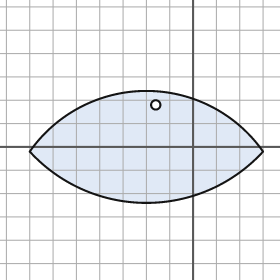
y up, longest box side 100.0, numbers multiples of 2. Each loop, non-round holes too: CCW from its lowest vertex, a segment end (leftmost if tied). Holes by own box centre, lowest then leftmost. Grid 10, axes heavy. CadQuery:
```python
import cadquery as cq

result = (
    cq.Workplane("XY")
    .moveTo(-70.0, -2.0)
    .threePointArc((-20.0, -24.0), (30.0, -2.0))
    .threePointArc((-20.0, 24.0), (-70.0, -2.0))
    .close()
    .moveTo(-16.0, 18.0)
    .circle(2.0)
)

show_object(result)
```